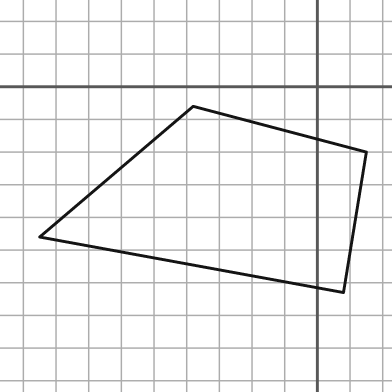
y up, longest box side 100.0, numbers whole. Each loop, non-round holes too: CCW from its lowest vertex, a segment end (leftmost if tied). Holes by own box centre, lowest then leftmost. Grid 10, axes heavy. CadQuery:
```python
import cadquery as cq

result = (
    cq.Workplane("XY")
    .moveTo(8.0, -63.0)
    .lineTo(15.0, -20.0)
    .lineTo(-38.0, -6.0)
    .lineTo(-85.0, -46.0)
    .close()
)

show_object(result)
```